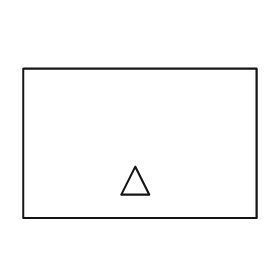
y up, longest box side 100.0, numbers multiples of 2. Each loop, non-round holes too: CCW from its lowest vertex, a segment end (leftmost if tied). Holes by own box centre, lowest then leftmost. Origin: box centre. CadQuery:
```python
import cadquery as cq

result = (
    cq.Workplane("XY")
    .moveTo(-50.0, -32.0)
    .lineTo(50.0, -32.0)
    .lineTo(50.0, 32.0)
    .lineTo(-50.0, 32.0)
    .close()
    .moveTo(-8.0, -22.0)
    .lineTo(4.0, -22.0)
    .lineTo(-2.0, -10.0)
    .close()
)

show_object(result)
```